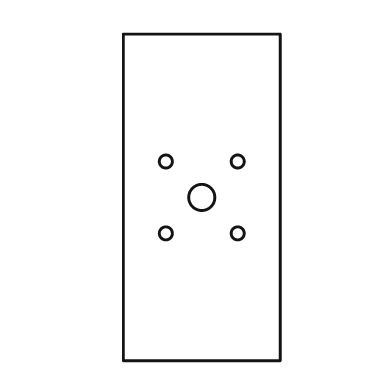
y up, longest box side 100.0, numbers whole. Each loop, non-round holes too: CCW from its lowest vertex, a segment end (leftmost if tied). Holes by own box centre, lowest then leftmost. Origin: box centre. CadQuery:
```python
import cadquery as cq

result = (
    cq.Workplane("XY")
    .moveTo(-24.0, -50.0)
    .lineTo(24.0, -50.0)
    .lineTo(24.0, 50.0)
    .lineTo(-24.0, 50.0)
    .close()
    .moveTo(-11.0, -11.0)
    .circle(2.0)
    .moveTo(11.0, -11.0)
    .circle(2.0)
    .moveTo(0.0, 0.0)
    .circle(4.0)
    .moveTo(-11.0, 11.0)
    .circle(2.0)
    .moveTo(11.0, 11.0)
    .circle(2.0)
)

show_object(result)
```